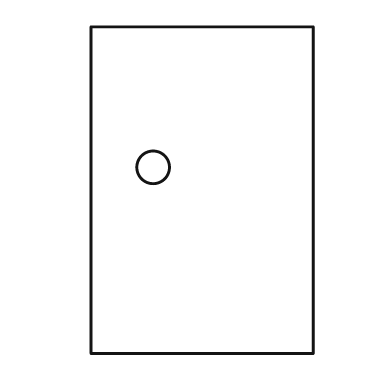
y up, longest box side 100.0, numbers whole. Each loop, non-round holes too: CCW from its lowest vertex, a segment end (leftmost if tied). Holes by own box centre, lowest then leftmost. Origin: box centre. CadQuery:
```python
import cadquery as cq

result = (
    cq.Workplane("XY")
    .moveTo(-34.0, -50.0)
    .lineTo(34.0, -50.0)
    .lineTo(34.0, 50.0)
    .lineTo(-34.0, 50.0)
    .close()
    .moveTo(-15.0, 7.0)
    .circle(5.0)
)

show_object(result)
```